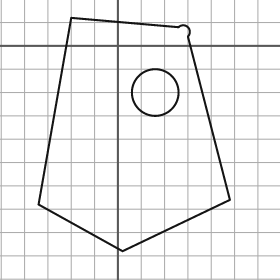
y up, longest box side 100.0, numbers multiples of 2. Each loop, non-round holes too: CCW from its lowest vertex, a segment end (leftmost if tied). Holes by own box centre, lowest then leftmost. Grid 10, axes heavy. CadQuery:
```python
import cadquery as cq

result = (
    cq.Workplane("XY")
    .moveTo(2.0, -88.0)
    .lineTo(48.0, -66.0)
    .lineTo(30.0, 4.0)
    .threePointArc((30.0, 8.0), (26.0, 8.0))
    .lineTo(-20.0, 12.0)
    .lineTo(-34.0, -68.0)
    .close()
    .moveTo(16.0, -20.0)
    .circle(10.0)
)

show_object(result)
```